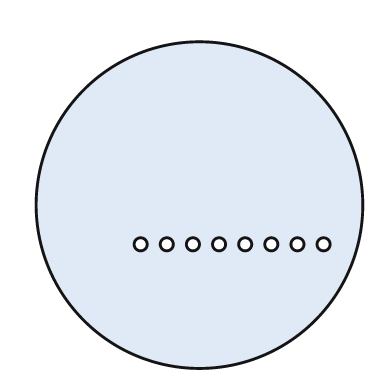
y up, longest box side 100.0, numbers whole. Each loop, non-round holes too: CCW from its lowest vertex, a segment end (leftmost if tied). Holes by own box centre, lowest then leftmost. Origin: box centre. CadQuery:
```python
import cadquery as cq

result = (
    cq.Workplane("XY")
    .moveTo(0.0, 0.0)
    .circle(50.0)
    .moveTo(-18.0, -12.0)
    .circle(2.0)
    .moveTo(-10.0, -12.0)
    .circle(2.0)
    .moveTo(-2.0, -12.0)
    .circle(2.0)
    .moveTo(6.0, -12.0)
    .circle(2.0)
    .moveTo(14.0, -12.0)
    .circle(2.0)
    .moveTo(22.0, -12.0)
    .circle(2.0)
    .moveTo(30.0, -12.0)
    .circle(2.0)
    .moveTo(38.0, -12.0)
    .circle(2.0)
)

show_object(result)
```